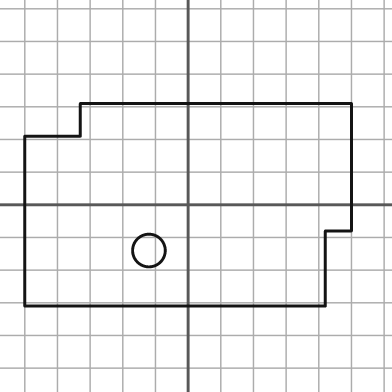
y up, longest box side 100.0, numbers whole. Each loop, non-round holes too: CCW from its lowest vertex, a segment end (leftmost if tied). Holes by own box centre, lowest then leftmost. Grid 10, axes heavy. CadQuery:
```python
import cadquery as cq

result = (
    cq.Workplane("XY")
    .moveTo(-50.0, -31.0)
    .lineTo(42.0, -31.0)
    .lineTo(42.0, -8.0)
    .lineTo(50.0, -8.0)
    .lineTo(50.0, 31.0)
    .lineTo(-33.0, 31.0)
    .lineTo(-33.0, 21.0)
    .lineTo(-50.0, 21.0)
    .close()
    .moveTo(-12.0, -14.0)
    .circle(5.0)
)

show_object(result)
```